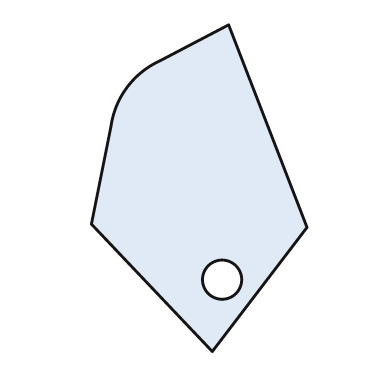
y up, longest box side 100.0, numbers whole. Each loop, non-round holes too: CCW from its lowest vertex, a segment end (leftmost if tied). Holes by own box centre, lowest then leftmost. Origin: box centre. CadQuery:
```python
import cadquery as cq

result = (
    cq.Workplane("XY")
    .moveTo(4.0, -50.0)
    .lineTo(33.0, -12.0)
    .lineTo(9.0, 50.0)
    .lineTo(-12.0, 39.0)
    .threePointArc((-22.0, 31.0), (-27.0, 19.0))
    .lineTo(-33.0, -11.0)
    .close()
    .moveTo(7.0, -28.0)
    .circle(6.0)
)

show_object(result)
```